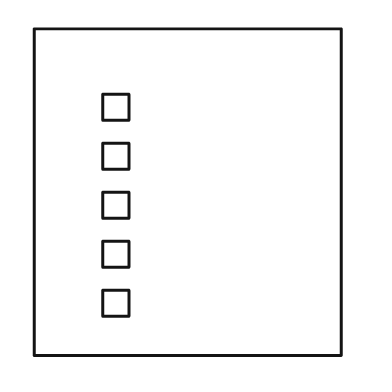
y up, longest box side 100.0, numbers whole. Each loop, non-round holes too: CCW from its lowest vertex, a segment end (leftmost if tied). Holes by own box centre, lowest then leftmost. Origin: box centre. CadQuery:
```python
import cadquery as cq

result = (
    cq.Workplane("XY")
    .moveTo(-47.0, -50.0)
    .lineTo(47.0, -50.0)
    .lineTo(47.0, 50.0)
    .lineTo(-47.0, 50.0)
    .close()
    .moveTo(-26.0, -38.0)
    .lineTo(-18.0, -38.0)
    .lineTo(-18.0, -30.0)
    .lineTo(-26.0, -30.0)
    .close()
    .moveTo(-26.0, -23.0)
    .lineTo(-18.0, -23.0)
    .lineTo(-18.0, -15.0)
    .lineTo(-26.0, -15.0)
    .close()
    .moveTo(-26.0, -8.0)
    .lineTo(-18.0, -8.0)
    .lineTo(-18.0, 0.0)
    .lineTo(-26.0, 0.0)
    .close()
    .moveTo(-26.0, 7.0)
    .lineTo(-18.0, 7.0)
    .lineTo(-18.0, 15.0)
    .lineTo(-26.0, 15.0)
    .close()
    .moveTo(-26.0, 22.0)
    .lineTo(-18.0, 22.0)
    .lineTo(-18.0, 30.0)
    .lineTo(-26.0, 30.0)
    .close()
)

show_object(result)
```